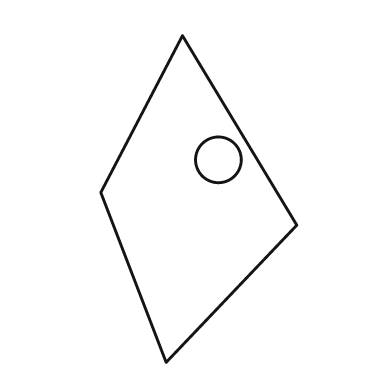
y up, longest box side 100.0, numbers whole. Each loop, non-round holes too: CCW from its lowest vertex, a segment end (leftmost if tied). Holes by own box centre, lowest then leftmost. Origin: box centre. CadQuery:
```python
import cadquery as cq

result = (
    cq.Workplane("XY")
    .moveTo(-10.0, -50.0)
    .lineTo(30.0, -8.0)
    .lineTo(-5.0, 50.0)
    .lineTo(-30.0, 2.0)
    .close()
    .moveTo(6.0, 12.0)
    .circle(7.0)
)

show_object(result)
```